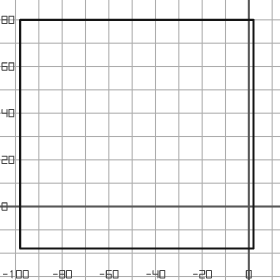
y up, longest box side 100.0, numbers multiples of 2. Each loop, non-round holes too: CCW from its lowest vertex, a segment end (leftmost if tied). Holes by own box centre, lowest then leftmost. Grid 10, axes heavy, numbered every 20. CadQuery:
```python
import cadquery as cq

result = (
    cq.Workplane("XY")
    .moveTo(-98.0, -18.0)
    .lineTo(2.0, -18.0)
    .lineTo(2.0, 80.0)
    .lineTo(-98.0, 80.0)
    .close()
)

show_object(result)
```